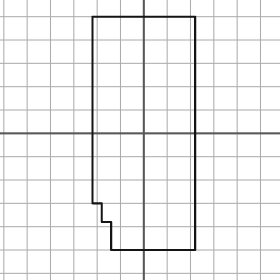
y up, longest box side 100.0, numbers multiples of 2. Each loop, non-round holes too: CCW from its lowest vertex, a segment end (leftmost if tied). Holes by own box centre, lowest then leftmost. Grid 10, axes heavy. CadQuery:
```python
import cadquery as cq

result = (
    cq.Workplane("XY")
    .moveTo(-14.0, -50.0)
    .lineTo(22.0, -50.0)
    .lineTo(22.0, 50.0)
    .lineTo(-22.0, 50.0)
    .lineTo(-22.0, -30.0)
    .lineTo(-18.0, -30.0)
    .lineTo(-18.0, -38.0)
    .lineTo(-14.0, -38.0)
    .close()
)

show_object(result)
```